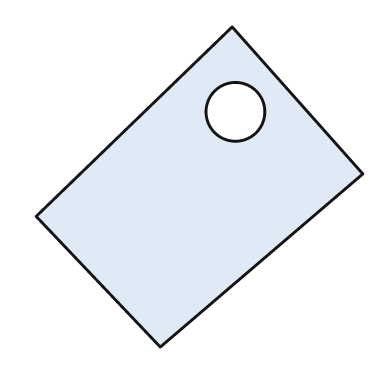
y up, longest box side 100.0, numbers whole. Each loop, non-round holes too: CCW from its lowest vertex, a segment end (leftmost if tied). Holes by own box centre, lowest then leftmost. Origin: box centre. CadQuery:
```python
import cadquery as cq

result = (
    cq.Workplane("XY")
    .moveTo(-12.0, -49.0)
    .lineTo(50.0, 4.0)
    .lineTo(10.0, 49.0)
    .lineTo(-50.0, -9.0)
    .close()
    .moveTo(11.0, 23.0)
    .circle(9.0)
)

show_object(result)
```